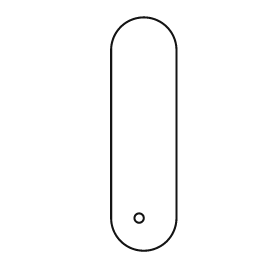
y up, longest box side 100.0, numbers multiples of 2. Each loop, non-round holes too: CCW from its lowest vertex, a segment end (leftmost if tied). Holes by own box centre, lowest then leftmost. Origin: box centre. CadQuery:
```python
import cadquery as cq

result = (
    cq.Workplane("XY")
    .moveTo(-14.0, -36.0)
    .threePointArc((0.0, -50.0), (14.0, -36.0))
    .lineTo(14.0, 36.0)
    .threePointArc((0.0, 50.0), (-14.0, 36.0))
    .close()
    .moveTo(-2.0, -36.0)
    .circle(2.0)
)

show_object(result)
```